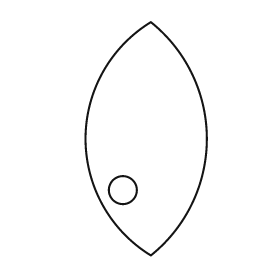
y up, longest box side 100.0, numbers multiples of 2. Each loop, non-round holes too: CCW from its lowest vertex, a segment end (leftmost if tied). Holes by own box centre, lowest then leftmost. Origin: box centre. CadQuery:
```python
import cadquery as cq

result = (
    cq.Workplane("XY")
    .moveTo(2.0, -50.0)
    .threePointArc((26.0, 0.0), (2.0, 50.0))
    .threePointArc((-26.0, 0.0), (2.0, -50.0))
    .close()
    .moveTo(-10.0, -22.0)
    .circle(6.0)
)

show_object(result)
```